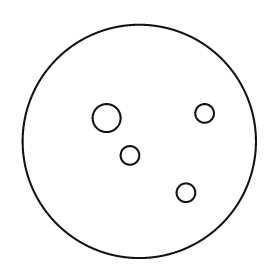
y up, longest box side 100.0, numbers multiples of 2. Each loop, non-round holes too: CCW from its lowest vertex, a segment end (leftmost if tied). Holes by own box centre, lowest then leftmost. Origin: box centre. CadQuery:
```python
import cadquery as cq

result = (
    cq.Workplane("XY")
    .moveTo(0.0, 0.0)
    .circle(50.0)
    .moveTo(20.0, -22.0)
    .circle(4.0)
    .moveTo(-4.0, -6.0)
    .circle(4.0)
    .moveTo(-14.0, 10.0)
    .circle(6.0)
    .moveTo(28.0, 12.0)
    .circle(4.0)
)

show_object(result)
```